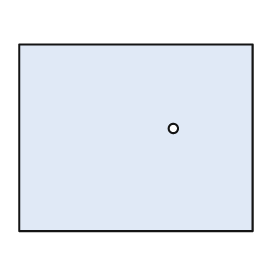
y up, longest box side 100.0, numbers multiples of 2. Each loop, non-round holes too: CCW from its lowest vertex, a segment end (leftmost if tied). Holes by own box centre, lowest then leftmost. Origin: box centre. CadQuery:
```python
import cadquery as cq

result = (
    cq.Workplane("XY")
    .moveTo(-50.0, -40.0)
    .lineTo(50.0, -40.0)
    .lineTo(50.0, 40.0)
    .lineTo(-50.0, 40.0)
    .close()
    .moveTo(16.0, 4.0)
    .circle(2.0)
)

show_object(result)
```